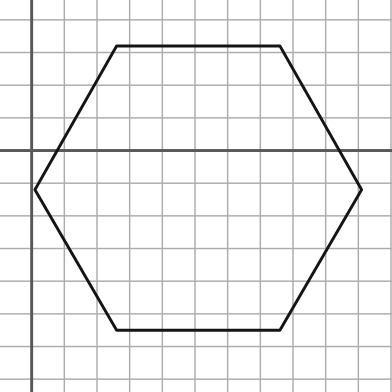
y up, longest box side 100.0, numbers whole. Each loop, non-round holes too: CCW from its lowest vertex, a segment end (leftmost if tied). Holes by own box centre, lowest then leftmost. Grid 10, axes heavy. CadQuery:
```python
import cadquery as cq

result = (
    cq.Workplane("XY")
    .moveTo(26.0, -55.0)
    .lineTo(76.0, -55.0)
    .lineTo(101.0, -12.0)
    .lineTo(76.0, 32.0)
    .lineTo(26.0, 32.0)
    .lineTo(1.0, -12.0)
    .close()
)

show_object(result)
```